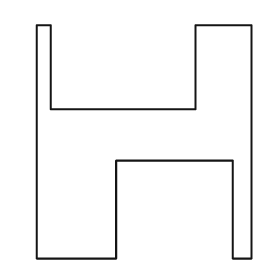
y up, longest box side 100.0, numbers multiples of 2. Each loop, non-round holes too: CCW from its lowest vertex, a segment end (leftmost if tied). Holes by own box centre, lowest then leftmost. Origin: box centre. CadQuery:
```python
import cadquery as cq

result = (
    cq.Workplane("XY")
    .moveTo(-46.0, -50.0)
    .lineTo(-12.0, -50.0)
    .lineTo(-12.0, -8.0)
    .lineTo(38.0, -8.0)
    .lineTo(38.0, -50.0)
    .lineTo(46.0, -50.0)
    .lineTo(46.0, 50.0)
    .lineTo(22.0, 50.0)
    .lineTo(22.0, 14.0)
    .lineTo(-40.0, 14.0)
    .lineTo(-40.0, 50.0)
    .lineTo(-46.0, 50.0)
    .close()
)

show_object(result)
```